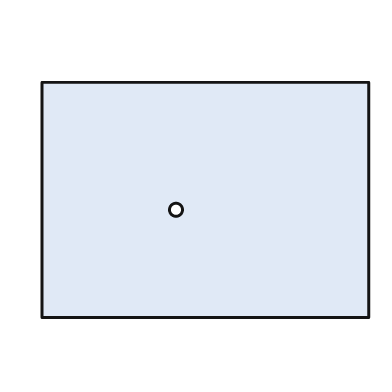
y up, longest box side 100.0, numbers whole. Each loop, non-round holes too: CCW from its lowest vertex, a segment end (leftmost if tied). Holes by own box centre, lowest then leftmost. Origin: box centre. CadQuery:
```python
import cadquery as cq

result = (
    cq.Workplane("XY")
    .moveTo(-50.0, -36.0)
    .lineTo(50.0, -36.0)
    .lineTo(50.0, 36.0)
    .lineTo(-50.0, 36.0)
    .close()
    .moveTo(-9.0, -3.0)
    .circle(2.0)
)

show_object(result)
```